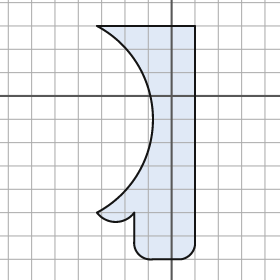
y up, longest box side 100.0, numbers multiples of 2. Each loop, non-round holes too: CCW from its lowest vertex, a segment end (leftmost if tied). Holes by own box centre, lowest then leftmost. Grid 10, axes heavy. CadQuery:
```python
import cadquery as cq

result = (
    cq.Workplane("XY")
    .moveTo(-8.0, -70.0)
    .lineTo(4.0, -70.0)
    .threePointArc((8.0, -68.0), (10.0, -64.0))
    .lineTo(10.0, 30.0)
    .lineTo(-32.0, 30.0)
    .threePointArc((-8.0, -10.0), (-32.0, -50.0))
    .threePointArc((-24.0, -54.0), (-16.0, -50.0))
    .lineTo(-16.0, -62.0)
    .threePointArc((-14.0, -68.0), (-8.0, -70.0))
    .close()
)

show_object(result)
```